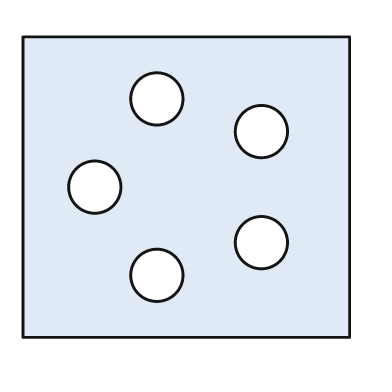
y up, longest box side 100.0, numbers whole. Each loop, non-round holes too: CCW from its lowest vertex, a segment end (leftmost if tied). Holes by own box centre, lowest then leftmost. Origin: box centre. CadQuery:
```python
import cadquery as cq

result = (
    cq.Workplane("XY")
    .moveTo(-50.0, -46.0)
    .lineTo(50.0, -46.0)
    .lineTo(50.0, 46.0)
    .lineTo(-50.0, 46.0)
    .close()
    .moveTo(-9.0, -27.0)
    .circle(8.0)
    .moveTo(23.0, -17.0)
    .circle(8.0)
    .moveTo(-28.0, 0.0)
    .circle(8.0)
    .moveTo(23.0, 17.0)
    .circle(8.0)
    .moveTo(-9.0, 27.0)
    .circle(8.0)
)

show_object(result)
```